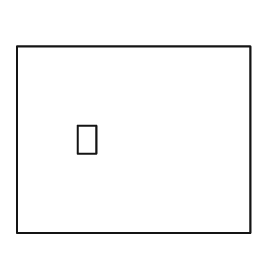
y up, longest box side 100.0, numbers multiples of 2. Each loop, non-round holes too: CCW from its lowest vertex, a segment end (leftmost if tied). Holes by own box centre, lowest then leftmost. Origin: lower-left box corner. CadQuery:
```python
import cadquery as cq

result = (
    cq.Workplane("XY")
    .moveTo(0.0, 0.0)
    .lineTo(100.0, 0.0)
    .lineTo(100.0, 80.0)
    .lineTo(0.0, 80.0)
    .close()
    .moveTo(26.0, 34.0)
    .lineTo(34.0, 34.0)
    .lineTo(34.0, 46.0)
    .lineTo(26.0, 46.0)
    .close()
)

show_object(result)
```